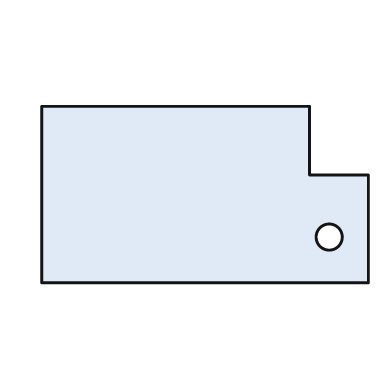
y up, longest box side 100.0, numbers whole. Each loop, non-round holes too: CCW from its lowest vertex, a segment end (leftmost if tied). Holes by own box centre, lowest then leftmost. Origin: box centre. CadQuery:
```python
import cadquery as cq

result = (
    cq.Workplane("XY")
    .moveTo(-50.0, -27.0)
    .lineTo(50.0, -27.0)
    .lineTo(50.0, 6.0)
    .lineTo(32.0, 6.0)
    .lineTo(32.0, 27.0)
    .lineTo(-50.0, 27.0)
    .close()
    .moveTo(38.0, -13.0)
    .circle(4.0)
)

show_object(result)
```